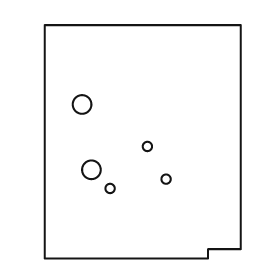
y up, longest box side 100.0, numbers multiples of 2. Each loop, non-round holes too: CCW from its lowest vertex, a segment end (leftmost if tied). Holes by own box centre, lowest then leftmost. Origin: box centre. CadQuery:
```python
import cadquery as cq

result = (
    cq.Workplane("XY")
    .moveTo(-42.0, -50.0)
    .lineTo(28.0, -50.0)
    .lineTo(28.0, -46.0)
    .lineTo(42.0, -46.0)
    .lineTo(42.0, 50.0)
    .lineTo(-42.0, 50.0)
    .close()
    .moveTo(-14.0, -20.0)
    .circle(2.0)
    .moveTo(10.0, -16.0)
    .circle(2.0)
    .moveTo(-22.0, -12.0)
    .circle(4.0)
    .moveTo(2.0, -2.0)
    .circle(2.0)
    .moveTo(-26.0, 16.0)
    .circle(4.0)
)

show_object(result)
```